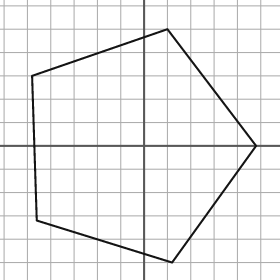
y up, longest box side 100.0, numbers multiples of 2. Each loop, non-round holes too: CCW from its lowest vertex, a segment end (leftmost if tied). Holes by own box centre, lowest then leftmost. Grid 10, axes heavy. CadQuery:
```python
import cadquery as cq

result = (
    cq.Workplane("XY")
    .moveTo(12.0, -50.0)
    .lineTo(48.0, 0.0)
    .lineTo(10.0, 50.0)
    .lineTo(-48.0, 30.0)
    .lineTo(-46.0, -32.0)
    .close()
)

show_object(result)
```